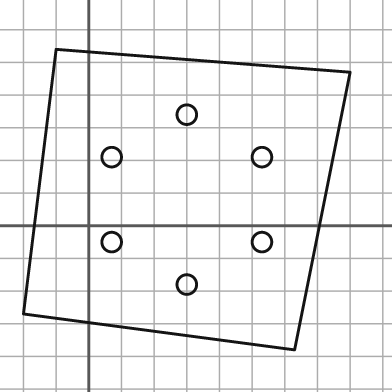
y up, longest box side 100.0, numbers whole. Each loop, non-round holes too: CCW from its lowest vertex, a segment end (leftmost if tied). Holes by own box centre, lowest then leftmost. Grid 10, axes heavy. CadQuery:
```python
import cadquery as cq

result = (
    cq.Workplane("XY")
    .moveTo(63.0, -38.0)
    .lineTo(80.0, 47.0)
    .lineTo(-10.0, 54.0)
    .lineTo(-20.0, -27.0)
    .close()
    .moveTo(30.0, -18.0)
    .circle(3.0)
    .moveTo(7.0, -5.0)
    .circle(3.0)
    .moveTo(53.0, -5.0)
    .circle(3.0)
    .moveTo(7.0, 21.0)
    .circle(3.0)
    .moveTo(53.0, 21.0)
    .circle(3.0)
    .moveTo(30.0, 34.0)
    .circle(3.0)
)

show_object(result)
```